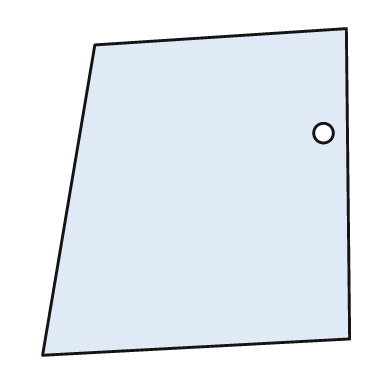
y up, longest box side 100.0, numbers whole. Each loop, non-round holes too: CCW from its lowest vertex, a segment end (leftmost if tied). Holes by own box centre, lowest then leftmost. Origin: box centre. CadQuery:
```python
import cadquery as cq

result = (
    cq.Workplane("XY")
    .moveTo(-47.0, -50.0)
    .lineTo(47.0, -45.0)
    .lineTo(46.0, 50.0)
    .lineTo(-31.0, 45.0)
    .close()
    .moveTo(39.0, 18.0)
    .circle(3.0)
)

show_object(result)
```